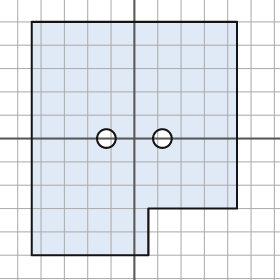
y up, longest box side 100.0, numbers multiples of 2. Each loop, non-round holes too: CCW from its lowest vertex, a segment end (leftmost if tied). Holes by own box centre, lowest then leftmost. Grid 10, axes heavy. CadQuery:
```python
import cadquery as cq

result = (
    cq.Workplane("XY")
    .moveTo(-44.0, -50.0)
    .lineTo(6.0, -50.0)
    .lineTo(6.0, -30.0)
    .lineTo(44.0, -30.0)
    .lineTo(44.0, 50.0)
    .lineTo(-44.0, 50.0)
    .close()
    .moveTo(-12.0, 0.0)
    .circle(4.0)
    .moveTo(12.0, 0.0)
    .circle(4.0)
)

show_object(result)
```